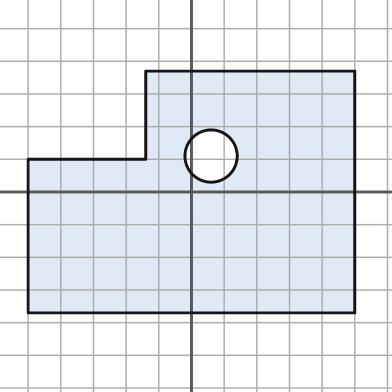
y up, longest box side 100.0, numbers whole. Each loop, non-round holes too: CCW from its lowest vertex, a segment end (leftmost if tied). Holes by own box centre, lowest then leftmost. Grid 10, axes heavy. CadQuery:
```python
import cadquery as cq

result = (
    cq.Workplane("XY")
    .moveTo(-50.0, -37.0)
    .lineTo(50.0, -37.0)
    .lineTo(50.0, 37.0)
    .lineTo(-14.0, 37.0)
    .lineTo(-14.0, 10.0)
    .lineTo(-50.0, 10.0)
    .close()
    .moveTo(6.0, 11.0)
    .circle(8.0)
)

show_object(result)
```